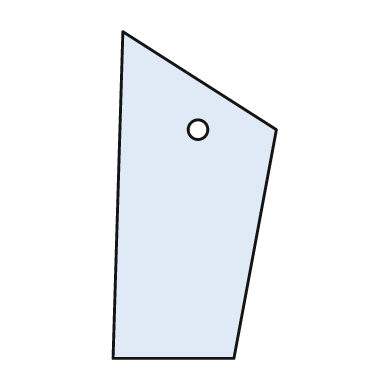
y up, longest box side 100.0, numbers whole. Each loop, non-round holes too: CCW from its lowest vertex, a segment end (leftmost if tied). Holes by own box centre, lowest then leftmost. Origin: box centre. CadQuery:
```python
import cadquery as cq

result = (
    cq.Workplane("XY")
    .moveTo(-25.0, -50.0)
    .lineTo(12.0, -50.0)
    .lineTo(25.0, 20.0)
    .lineTo(-22.0, 50.0)
    .close()
    .moveTo(1.0, 20.0)
    .circle(3.0)
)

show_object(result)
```